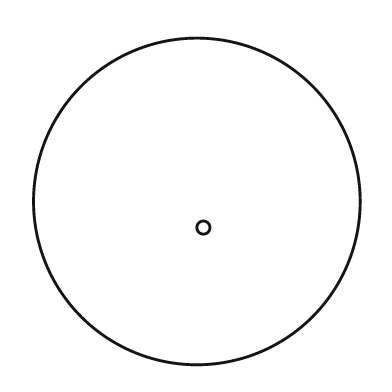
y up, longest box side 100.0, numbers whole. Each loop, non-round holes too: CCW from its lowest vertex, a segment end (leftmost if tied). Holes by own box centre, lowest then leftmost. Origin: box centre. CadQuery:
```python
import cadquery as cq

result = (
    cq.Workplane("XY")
    .moveTo(0.0, 0.0)
    .circle(50.0)
    .moveTo(2.0, -8.0)
    .circle(2.0)
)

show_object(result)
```